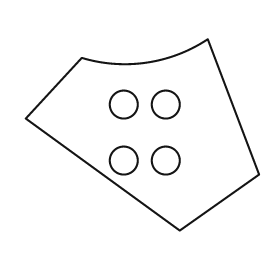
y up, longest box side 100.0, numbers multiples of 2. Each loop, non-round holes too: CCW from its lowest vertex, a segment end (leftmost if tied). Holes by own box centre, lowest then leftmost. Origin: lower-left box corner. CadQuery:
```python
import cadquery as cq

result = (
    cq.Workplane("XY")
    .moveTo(66.0, 0.0)
    .lineTo(100.0, 24.0)
    .lineTo(78.0, 82.0)
    .threePointArc((52.0, 72.0), (24.0, 74.0))
    .lineTo(0.0, 48.0)
    .close()
    .moveTo(42.0, 30.0)
    .circle(6.0)
    .moveTo(60.0, 30.0)
    .circle(6.0)
    .moveTo(42.0, 54.0)
    .circle(6.0)
    .moveTo(60.0, 54.0)
    .circle(6.0)
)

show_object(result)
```